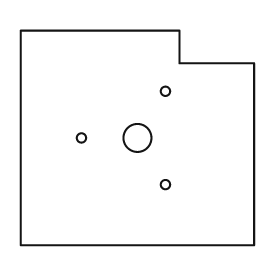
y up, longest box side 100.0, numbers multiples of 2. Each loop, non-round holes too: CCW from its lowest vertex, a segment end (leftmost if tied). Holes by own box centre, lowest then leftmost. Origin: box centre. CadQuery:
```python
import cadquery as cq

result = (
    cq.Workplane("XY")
    .moveTo(-50.0, -46.0)
    .lineTo(50.0, -46.0)
    .lineTo(50.0, 32.0)
    .lineTo(18.0, 32.0)
    .lineTo(18.0, 46.0)
    .lineTo(-50.0, 46.0)
    .close()
    .moveTo(12.0, -20.0)
    .circle(2.0)
    .moveTo(-24.0, 0.0)
    .circle(2.0)
    .moveTo(0.0, 0.0)
    .circle(6.0)
    .moveTo(12.0, 20.0)
    .circle(2.0)
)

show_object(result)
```